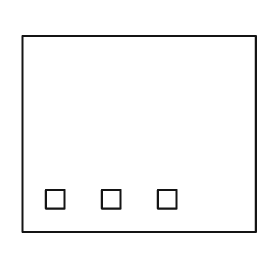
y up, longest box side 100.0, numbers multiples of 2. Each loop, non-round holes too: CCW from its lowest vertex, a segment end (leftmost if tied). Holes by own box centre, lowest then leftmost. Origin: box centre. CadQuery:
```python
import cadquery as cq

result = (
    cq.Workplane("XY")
    .moveTo(-50.0, -42.0)
    .lineTo(50.0, -42.0)
    .lineTo(50.0, 42.0)
    .lineTo(-50.0, 42.0)
    .close()
    .moveTo(-40.0, -32.0)
    .lineTo(-32.0, -32.0)
    .lineTo(-32.0, -24.0)
    .lineTo(-40.0, -24.0)
    .close()
    .moveTo(-16.0, -32.0)
    .lineTo(-8.0, -32.0)
    .lineTo(-8.0, -24.0)
    .lineTo(-16.0, -24.0)
    .close()
    .moveTo(8.0, -32.0)
    .lineTo(16.0, -32.0)
    .lineTo(16.0, -24.0)
    .lineTo(8.0, -24.0)
    .close()
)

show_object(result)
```